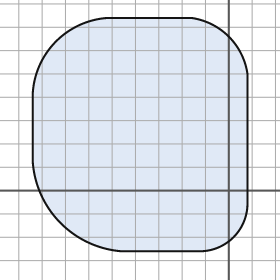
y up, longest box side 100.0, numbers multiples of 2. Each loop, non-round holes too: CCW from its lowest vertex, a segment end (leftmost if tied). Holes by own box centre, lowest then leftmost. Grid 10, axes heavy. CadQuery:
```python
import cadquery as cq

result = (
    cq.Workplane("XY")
    .moveTo(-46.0, -26.0)
    .lineTo(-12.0, -26.0)
    .threePointArc((2.0, -20.0), (8.0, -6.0))
    .lineTo(8.0, 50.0)
    .threePointArc((0.0, 66.0), (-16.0, 74.0))
    .lineTo(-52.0, 74.0)
    .threePointArc((-74.0, 64.0), (-84.0, 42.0))
    .lineTo(-84.0, 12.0)
    .threePointArc((-72.0, -14.0), (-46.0, -26.0))
    .close()
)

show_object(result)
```